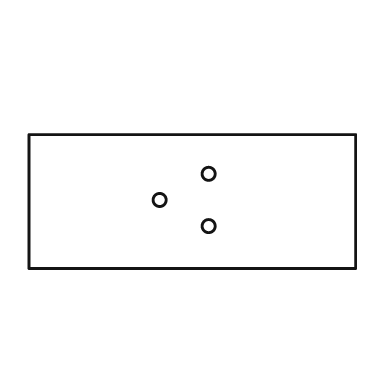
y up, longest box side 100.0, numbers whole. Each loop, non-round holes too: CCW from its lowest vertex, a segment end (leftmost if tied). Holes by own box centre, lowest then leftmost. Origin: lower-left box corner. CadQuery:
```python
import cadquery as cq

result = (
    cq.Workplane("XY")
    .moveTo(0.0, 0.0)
    .lineTo(100.0, 0.0)
    .lineTo(100.0, 41.0)
    .lineTo(0.0, 41.0)
    .close()
    .moveTo(55.0, 13.0)
    .circle(2.0)
    .moveTo(40.0, 21.0)
    .circle(2.0)
    .moveTo(55.0, 29.0)
    .circle(2.0)
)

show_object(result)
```